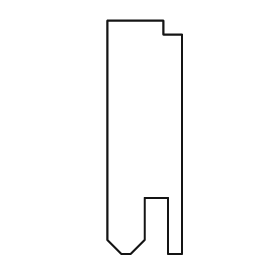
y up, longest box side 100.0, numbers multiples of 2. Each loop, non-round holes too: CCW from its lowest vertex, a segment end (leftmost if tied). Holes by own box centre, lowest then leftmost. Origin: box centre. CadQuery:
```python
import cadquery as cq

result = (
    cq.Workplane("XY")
    .moveTo(-10.0, -50.0)
    .lineTo(-6.0, -50.0)
    .lineTo(0.0, -44.0)
    .lineTo(0.0, -26.0)
    .lineTo(10.0, -26.0)
    .lineTo(10.0, -50.0)
    .lineTo(16.0, -50.0)
    .lineTo(16.0, 44.0)
    .lineTo(8.0, 44.0)
    .lineTo(8.0, 50.0)
    .lineTo(-16.0, 50.0)
    .lineTo(-16.0, -44.0)
    .close()
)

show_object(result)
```